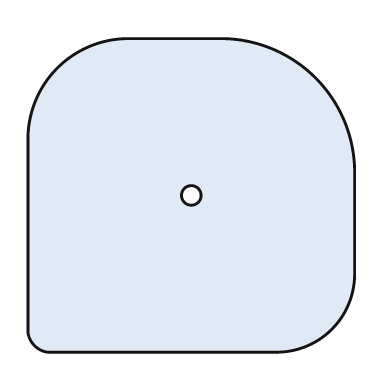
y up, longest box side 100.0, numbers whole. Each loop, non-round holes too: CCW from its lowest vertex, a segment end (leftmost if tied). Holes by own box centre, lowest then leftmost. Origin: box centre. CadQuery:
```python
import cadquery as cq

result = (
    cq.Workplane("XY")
    .moveTo(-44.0, -48.0)
    .lineTo(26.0, -48.0)
    .threePointArc((43.0, -41.0), (50.0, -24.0))
    .lineTo(50.0, 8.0)
    .threePointArc((38.0, 36.0), (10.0, 48.0))
    .lineTo(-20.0, 48.0)
    .threePointArc((-41.0, 39.0), (-50.0, 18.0))
    .lineTo(-50.0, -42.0)
    .threePointArc((-48.0, -46.0), (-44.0, -48.0))
    .close()
    .moveTo(0.0, 0.0)
    .circle(3.0)
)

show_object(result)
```